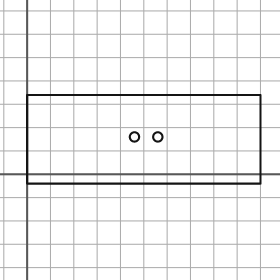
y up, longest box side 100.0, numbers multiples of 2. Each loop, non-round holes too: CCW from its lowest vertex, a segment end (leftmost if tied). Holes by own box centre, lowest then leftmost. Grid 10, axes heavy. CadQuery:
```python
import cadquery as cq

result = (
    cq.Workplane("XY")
    .moveTo(0.0, -4.0)
    .lineTo(100.0, -4.0)
    .lineTo(100.0, 34.0)
    .lineTo(0.0, 34.0)
    .close()
    .moveTo(46.0, 16.0)
    .circle(2.0)
    .moveTo(56.0, 16.0)
    .circle(2.0)
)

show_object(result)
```